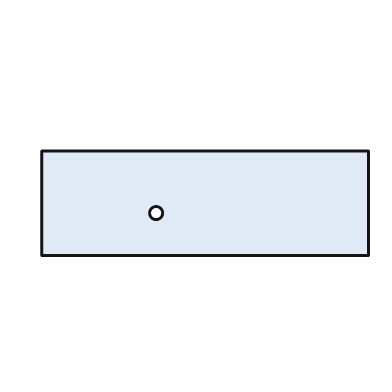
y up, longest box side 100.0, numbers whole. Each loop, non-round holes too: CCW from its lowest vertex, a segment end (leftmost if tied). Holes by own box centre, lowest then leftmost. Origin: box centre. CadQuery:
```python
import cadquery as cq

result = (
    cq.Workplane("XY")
    .moveTo(-50.0, -16.0)
    .lineTo(50.0, -16.0)
    .lineTo(50.0, 16.0)
    .lineTo(-50.0, 16.0)
    .close()
    .moveTo(-15.0, -3.0)
    .circle(2.0)
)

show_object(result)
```